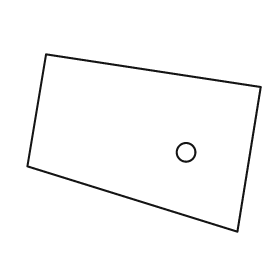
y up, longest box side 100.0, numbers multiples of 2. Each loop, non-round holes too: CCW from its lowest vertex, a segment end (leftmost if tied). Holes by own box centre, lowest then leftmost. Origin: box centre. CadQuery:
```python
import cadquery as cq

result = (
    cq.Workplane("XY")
    .moveTo(40.0, -38.0)
    .lineTo(50.0, 24.0)
    .lineTo(-42.0, 38.0)
    .lineTo(-50.0, -10.0)
    .close()
    .moveTo(18.0, -4.0)
    .circle(4.0)
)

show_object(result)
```